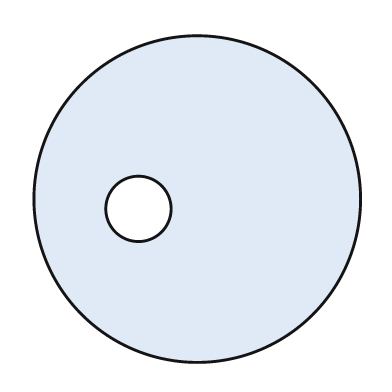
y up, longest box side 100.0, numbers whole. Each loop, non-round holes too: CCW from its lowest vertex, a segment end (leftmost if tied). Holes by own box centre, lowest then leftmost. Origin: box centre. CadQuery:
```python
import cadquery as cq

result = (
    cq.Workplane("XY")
    .moveTo(0.0, 0.0)
    .circle(50.0)
    .moveTo(-18.0, -3.0)
    .circle(10.0)
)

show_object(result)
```